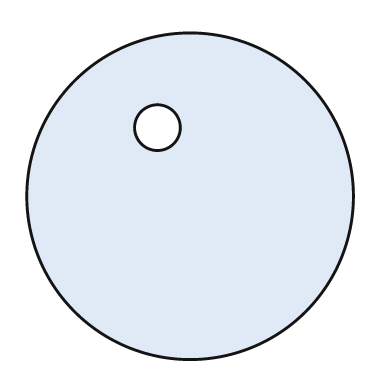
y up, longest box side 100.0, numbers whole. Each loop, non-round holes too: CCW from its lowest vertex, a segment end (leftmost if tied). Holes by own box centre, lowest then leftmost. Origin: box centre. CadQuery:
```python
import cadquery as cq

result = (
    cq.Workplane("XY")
    .moveTo(0.0, 0.0)
    .circle(50.0)
    .moveTo(-10.0, 21.0)
    .circle(7.0)
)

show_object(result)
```